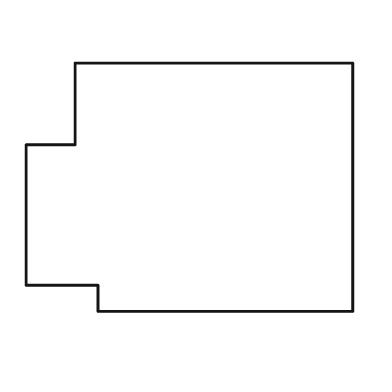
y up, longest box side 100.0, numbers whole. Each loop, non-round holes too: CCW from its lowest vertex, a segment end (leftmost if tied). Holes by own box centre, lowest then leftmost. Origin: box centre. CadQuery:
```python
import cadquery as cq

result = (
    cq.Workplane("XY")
    .moveTo(-28.0, -38.0)
    .lineTo(50.0, -38.0)
    .lineTo(50.0, 38.0)
    .lineTo(-35.0, 38.0)
    .lineTo(-35.0, 13.0)
    .lineTo(-50.0, 13.0)
    .lineTo(-50.0, -30.0)
    .lineTo(-28.0, -30.0)
    .close()
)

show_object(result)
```